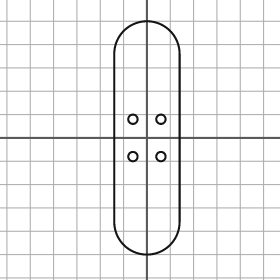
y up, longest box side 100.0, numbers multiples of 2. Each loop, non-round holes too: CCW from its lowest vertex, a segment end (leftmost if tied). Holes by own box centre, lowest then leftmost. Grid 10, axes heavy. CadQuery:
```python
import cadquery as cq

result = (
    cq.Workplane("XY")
    .moveTo(-14.0, -36.0)
    .threePointArc((0.0, -50.0), (14.0, -36.0))
    .lineTo(14.0, 36.0)
    .threePointArc((0.0, 50.0), (-14.0, 36.0))
    .close()
    .moveTo(-6.0, -8.0)
    .circle(2.0)
    .moveTo(6.0, -8.0)
    .circle(2.0)
    .moveTo(-6.0, 8.0)
    .circle(2.0)
    .moveTo(6.0, 8.0)
    .circle(2.0)
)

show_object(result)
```